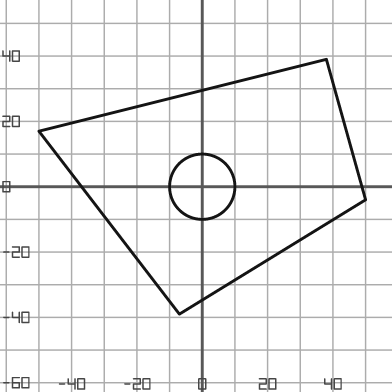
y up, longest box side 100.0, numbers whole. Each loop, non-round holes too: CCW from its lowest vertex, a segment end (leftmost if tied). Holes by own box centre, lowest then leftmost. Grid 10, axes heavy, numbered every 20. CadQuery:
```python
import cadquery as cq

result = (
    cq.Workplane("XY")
    .moveTo(-7.0, -39.0)
    .lineTo(50.0, -4.0)
    .lineTo(38.0, 39.0)
    .lineTo(-50.0, 17.0)
    .close()
    .moveTo(0.0, 0.0)
    .circle(10.0)
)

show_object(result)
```